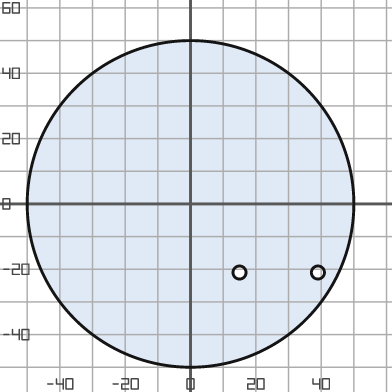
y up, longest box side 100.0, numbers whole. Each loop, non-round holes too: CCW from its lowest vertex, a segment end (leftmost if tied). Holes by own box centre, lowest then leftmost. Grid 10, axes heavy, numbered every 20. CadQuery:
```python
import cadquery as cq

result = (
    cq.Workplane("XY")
    .moveTo(0.0, 0.0)
    .circle(50.0)
    .moveTo(15.0, -21.0)
    .circle(2.0)
    .moveTo(39.0, -21.0)
    .circle(2.0)
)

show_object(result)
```